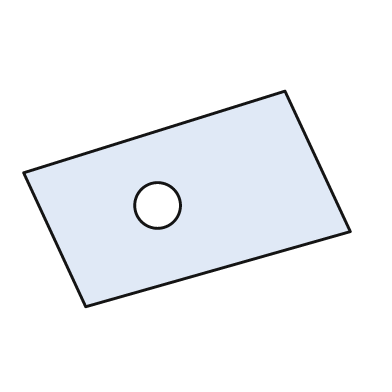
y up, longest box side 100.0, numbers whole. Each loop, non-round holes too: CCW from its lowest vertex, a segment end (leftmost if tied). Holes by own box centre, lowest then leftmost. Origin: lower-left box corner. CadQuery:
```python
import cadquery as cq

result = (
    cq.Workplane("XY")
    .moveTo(19.0, 0.0)
    .lineTo(100.0, 23.0)
    .lineTo(80.0, 66.0)
    .lineTo(0.0, 41.0)
    .close()
    .moveTo(41.0, 31.0)
    .circle(7.0)
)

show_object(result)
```